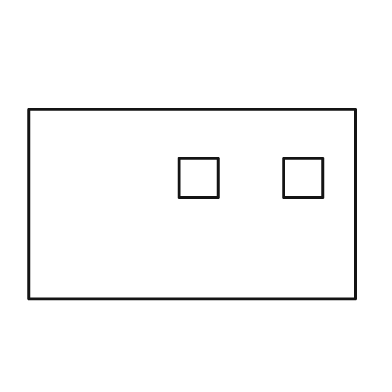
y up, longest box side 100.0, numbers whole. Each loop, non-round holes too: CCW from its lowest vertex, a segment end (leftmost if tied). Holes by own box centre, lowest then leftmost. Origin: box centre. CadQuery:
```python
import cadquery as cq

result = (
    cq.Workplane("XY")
    .moveTo(-50.0, -29.0)
    .lineTo(50.0, -29.0)
    .lineTo(50.0, 29.0)
    .lineTo(-50.0, 29.0)
    .close()
    .moveTo(-4.0, 2.0)
    .lineTo(8.0, 2.0)
    .lineTo(8.0, 14.0)
    .lineTo(-4.0, 14.0)
    .close()
    .moveTo(28.0, 2.0)
    .lineTo(40.0, 2.0)
    .lineTo(40.0, 14.0)
    .lineTo(28.0, 14.0)
    .close()
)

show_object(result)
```